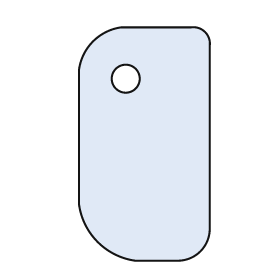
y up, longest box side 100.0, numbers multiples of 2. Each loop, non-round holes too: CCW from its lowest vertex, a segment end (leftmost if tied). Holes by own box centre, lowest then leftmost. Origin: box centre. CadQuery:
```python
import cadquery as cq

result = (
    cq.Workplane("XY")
    .moveTo(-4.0, -50.0)
    .lineTo(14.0, -50.0)
    .threePointArc((24.0, -46.0), (28.0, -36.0))
    .lineTo(28.0, 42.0)
    .threePointArc((26.0, 48.0), (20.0, 50.0))
    .lineTo(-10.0, 50.0)
    .threePointArc((-22.0, 44.0), (-28.0, 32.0))
    .lineTo(-28.0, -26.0)
    .threePointArc((-20.0, -42.0), (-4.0, -50.0))
    .close()
    .moveTo(-8.0, 28.0)
    .circle(6.0)
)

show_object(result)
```